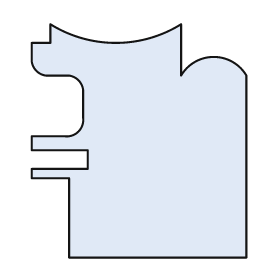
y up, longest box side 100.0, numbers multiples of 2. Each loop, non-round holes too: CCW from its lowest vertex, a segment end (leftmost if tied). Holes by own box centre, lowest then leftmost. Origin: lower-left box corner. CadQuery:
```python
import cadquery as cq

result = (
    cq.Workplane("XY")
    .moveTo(16.0, 0.0)
    .lineTo(92.0, 0.0)
    .lineTo(92.0, 78.0)
    .threePointArc((78.0, 86.0), (64.0, 78.0))
    .lineTo(64.0, 100.0)
    .threePointArc((36.0, 92.0), (8.0, 100.0))
    .lineTo(8.0, 92.0)
    .lineTo(0.0, 92.0)
    .lineTo(0.0, 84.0)
    .threePointArc((2.0, 80.0), (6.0, 78.0))
    .lineTo(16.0, 78.0)
    .threePointArc((20.0, 76.0), (22.0, 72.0))
    .lineTo(22.0, 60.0)
    .threePointArc((20.0, 54.0), (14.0, 52.0))
    .lineTo(0.0, 52.0)
    .lineTo(0.0, 46.0)
    .lineTo(24.0, 46.0)
    .lineTo(24.0, 38.0)
    .lineTo(0.0, 38.0)
    .lineTo(0.0, 34.0)
    .lineTo(16.0, 34.0)
    .close()
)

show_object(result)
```